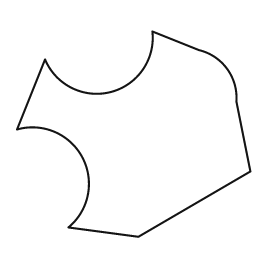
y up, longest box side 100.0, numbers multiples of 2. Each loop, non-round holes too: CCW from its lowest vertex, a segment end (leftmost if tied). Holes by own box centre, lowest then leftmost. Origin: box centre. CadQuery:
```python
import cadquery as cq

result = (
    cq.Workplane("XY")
    .moveTo(2.0, -44.0)
    .lineTo(50.0, -16.0)
    .lineTo(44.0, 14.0)
    .threePointArc((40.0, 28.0), (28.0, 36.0))
    .lineTo(8.0, 44.0)
    .threePointArc((-10.0, 18.0), (-38.0, 32.0))
    .lineTo(-50.0, 2.0)
    .threePointArc((-22.0, -10.0), (-28.0, -40.0))
    .close()
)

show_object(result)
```